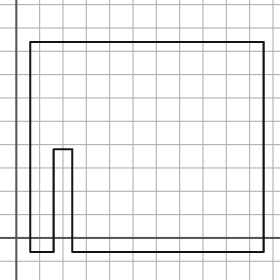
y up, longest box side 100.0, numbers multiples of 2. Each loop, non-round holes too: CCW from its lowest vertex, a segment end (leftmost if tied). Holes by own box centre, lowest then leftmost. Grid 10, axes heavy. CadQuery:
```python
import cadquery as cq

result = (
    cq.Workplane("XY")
    .moveTo(6.0, -6.0)
    .lineTo(16.0, -6.0)
    .lineTo(16.0, 38.0)
    .lineTo(24.0, 38.0)
    .lineTo(24.0, -6.0)
    .lineTo(106.0, -6.0)
    .lineTo(106.0, 84.0)
    .lineTo(6.0, 84.0)
    .close()
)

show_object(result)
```